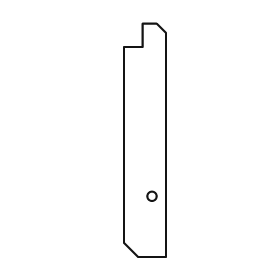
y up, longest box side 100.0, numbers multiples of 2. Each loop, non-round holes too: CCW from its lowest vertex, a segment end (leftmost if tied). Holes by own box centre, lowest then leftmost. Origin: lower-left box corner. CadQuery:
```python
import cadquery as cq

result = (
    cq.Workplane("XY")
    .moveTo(6.0, 0.0)
    .lineTo(18.0, 0.0)
    .lineTo(18.0, 96.0)
    .lineTo(14.0, 100.0)
    .lineTo(8.0, 100.0)
    .lineTo(8.0, 90.0)
    .lineTo(0.0, 90.0)
    .lineTo(0.0, 6.0)
    .close()
    .moveTo(12.0, 26.0)
    .circle(2.0)
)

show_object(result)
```